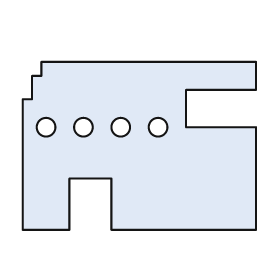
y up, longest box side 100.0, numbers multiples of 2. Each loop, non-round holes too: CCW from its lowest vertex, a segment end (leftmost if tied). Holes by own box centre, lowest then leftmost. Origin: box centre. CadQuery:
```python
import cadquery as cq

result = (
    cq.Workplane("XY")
    .moveTo(-50.0, -36.0)
    .lineTo(-30.0, -36.0)
    .lineTo(-30.0, -14.0)
    .lineTo(-12.0, -14.0)
    .lineTo(-12.0, -36.0)
    .lineTo(50.0, -36.0)
    .lineTo(50.0, 8.0)
    .lineTo(20.0, 8.0)
    .lineTo(20.0, 24.0)
    .lineTo(50.0, 24.0)
    .lineTo(50.0, 36.0)
    .lineTo(-42.0, 36.0)
    .lineTo(-42.0, 30.0)
    .lineTo(-46.0, 30.0)
    .lineTo(-46.0, 20.0)
    .lineTo(-50.0, 20.0)
    .close()
    .moveTo(-40.0, 8.0)
    .circle(4.0)
    .moveTo(-24.0, 8.0)
    .circle(4.0)
    .moveTo(-8.0, 8.0)
    .circle(4.0)
    .moveTo(8.0, 8.0)
    .circle(4.0)
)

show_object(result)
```